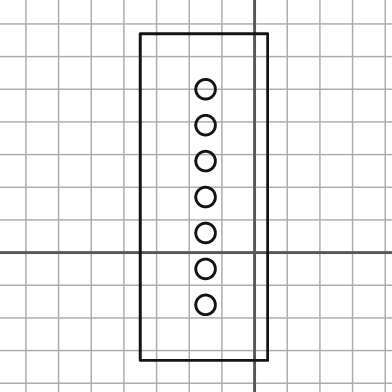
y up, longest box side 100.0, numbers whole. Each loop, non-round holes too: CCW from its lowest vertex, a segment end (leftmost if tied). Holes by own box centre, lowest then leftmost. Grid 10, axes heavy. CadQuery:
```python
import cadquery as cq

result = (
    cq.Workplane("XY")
    .moveTo(-35.0, -33.0)
    .lineTo(4.0, -33.0)
    .lineTo(4.0, 67.0)
    .lineTo(-35.0, 67.0)
    .close()
    .moveTo(-15.0, -16.0)
    .circle(3.0)
    .moveTo(-15.0, -5.0)
    .circle(3.0)
    .moveTo(-15.0, 6.0)
    .circle(3.0)
    .moveTo(-15.0, 17.0)
    .circle(3.0)
    .moveTo(-15.0, 28.0)
    .circle(3.0)
    .moveTo(-15.0, 39.0)
    .circle(3.0)
    .moveTo(-15.0, 50.0)
    .circle(3.0)
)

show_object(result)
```